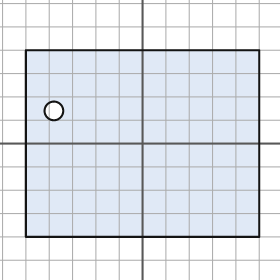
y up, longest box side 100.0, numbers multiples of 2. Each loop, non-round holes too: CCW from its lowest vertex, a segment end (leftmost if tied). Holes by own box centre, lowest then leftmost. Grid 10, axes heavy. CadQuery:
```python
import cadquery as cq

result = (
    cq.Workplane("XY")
    .moveTo(-50.0, -40.0)
    .lineTo(50.0, -40.0)
    .lineTo(50.0, 40.0)
    .lineTo(-50.0, 40.0)
    .close()
    .moveTo(-38.0, 14.0)
    .circle(4.0)
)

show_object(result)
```